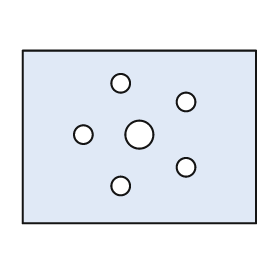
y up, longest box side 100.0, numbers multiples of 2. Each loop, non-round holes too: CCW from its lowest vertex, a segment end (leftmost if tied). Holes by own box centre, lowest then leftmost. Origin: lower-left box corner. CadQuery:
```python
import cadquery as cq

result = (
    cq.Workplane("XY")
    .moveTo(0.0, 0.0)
    .lineTo(100.0, 0.0)
    .lineTo(100.0, 74.0)
    .lineTo(0.0, 74.0)
    .close()
    .moveTo(42.0, 16.0)
    .circle(4.0)
    .moveTo(70.0, 24.0)
    .circle(4.0)
    .moveTo(26.0, 38.0)
    .circle(4.0)
    .moveTo(50.0, 38.0)
    .circle(6.0)
    .moveTo(70.0, 52.0)
    .circle(4.0)
    .moveTo(42.0, 60.0)
    .circle(4.0)
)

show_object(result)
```